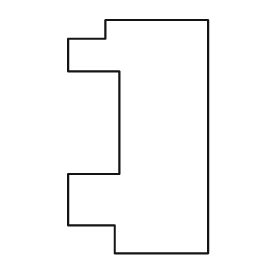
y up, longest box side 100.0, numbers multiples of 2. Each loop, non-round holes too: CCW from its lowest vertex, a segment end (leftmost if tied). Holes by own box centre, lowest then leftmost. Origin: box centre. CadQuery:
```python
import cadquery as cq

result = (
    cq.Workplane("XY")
    .moveTo(-10.0, -50.0)
    .lineTo(30.0, -50.0)
    .lineTo(30.0, 50.0)
    .lineTo(-14.0, 50.0)
    .lineTo(-14.0, 42.0)
    .lineTo(-30.0, 42.0)
    .lineTo(-30.0, 28.0)
    .lineTo(-8.0, 28.0)
    .lineTo(-8.0, -16.0)
    .lineTo(-30.0, -16.0)
    .lineTo(-30.0, -38.0)
    .lineTo(-10.0, -38.0)
    .close()
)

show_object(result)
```